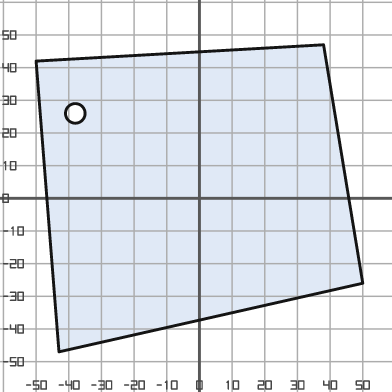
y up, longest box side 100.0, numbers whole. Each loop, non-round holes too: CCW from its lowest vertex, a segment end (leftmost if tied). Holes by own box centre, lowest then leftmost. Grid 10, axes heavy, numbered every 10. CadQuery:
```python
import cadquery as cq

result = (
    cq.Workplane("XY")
    .moveTo(-43.0, -47.0)
    .lineTo(50.0, -26.0)
    .lineTo(38.0, 47.0)
    .lineTo(-50.0, 42.0)
    .close()
    .moveTo(-38.0, 26.0)
    .circle(3.0)
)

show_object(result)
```